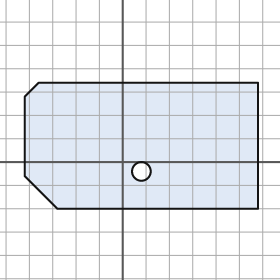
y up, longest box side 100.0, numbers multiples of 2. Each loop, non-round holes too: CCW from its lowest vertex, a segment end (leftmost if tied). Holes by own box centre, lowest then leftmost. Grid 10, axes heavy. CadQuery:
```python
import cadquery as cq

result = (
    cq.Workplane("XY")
    .moveTo(-28.0, -20.0)
    .lineTo(58.0, -20.0)
    .lineTo(58.0, 34.0)
    .lineTo(-36.0, 34.0)
    .lineTo(-42.0, 28.0)
    .lineTo(-42.0, -6.0)
    .close()
    .moveTo(8.0, -4.0)
    .circle(4.0)
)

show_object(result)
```